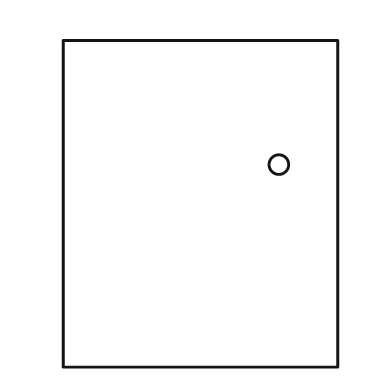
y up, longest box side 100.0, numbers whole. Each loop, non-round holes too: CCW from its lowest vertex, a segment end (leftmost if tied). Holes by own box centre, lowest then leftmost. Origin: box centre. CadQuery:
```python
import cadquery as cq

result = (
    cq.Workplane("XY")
    .moveTo(-42.0, -50.0)
    .lineTo(42.0, -50.0)
    .lineTo(42.0, 50.0)
    .lineTo(-42.0, 50.0)
    .close()
    .moveTo(24.0, 12.0)
    .circle(3.0)
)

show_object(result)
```